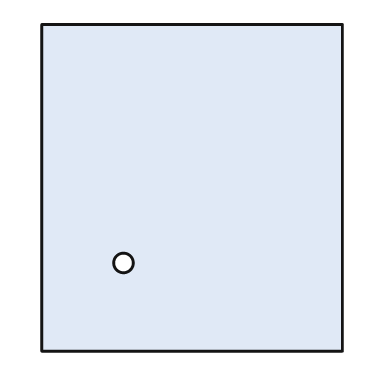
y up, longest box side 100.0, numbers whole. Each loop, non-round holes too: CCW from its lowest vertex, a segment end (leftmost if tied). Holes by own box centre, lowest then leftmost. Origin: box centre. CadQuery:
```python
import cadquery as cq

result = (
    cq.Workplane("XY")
    .moveTo(-46.0, -50.0)
    .lineTo(46.0, -50.0)
    .lineTo(46.0, 50.0)
    .lineTo(-46.0, 50.0)
    .close()
    .moveTo(-21.0, -23.0)
    .circle(3.0)
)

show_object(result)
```